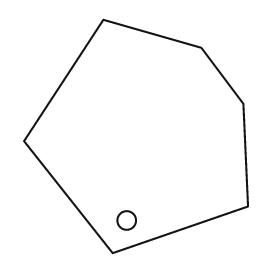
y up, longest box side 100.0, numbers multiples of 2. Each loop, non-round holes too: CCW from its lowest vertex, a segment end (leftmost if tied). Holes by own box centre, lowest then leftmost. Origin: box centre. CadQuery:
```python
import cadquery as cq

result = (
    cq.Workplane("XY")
    .moveTo(-10.0, -50.0)
    .lineTo(48.0, -30.0)
    .lineTo(46.0, 14.0)
    .lineTo(28.0, 38.0)
    .lineTo(-14.0, 50.0)
    .lineTo(-48.0, -2.0)
    .close()
    .moveTo(-4.0, -36.0)
    .circle(4.0)
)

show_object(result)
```